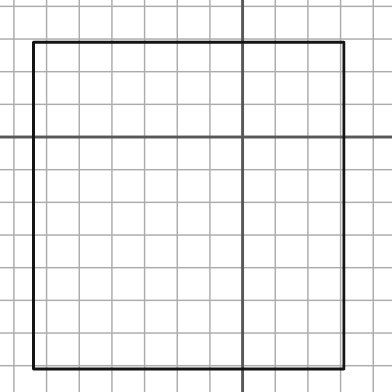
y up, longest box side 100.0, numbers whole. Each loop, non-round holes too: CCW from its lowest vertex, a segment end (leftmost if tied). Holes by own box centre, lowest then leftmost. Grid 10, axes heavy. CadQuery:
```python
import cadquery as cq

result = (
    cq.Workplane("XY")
    .moveTo(-64.0, -71.0)
    .lineTo(31.0, -71.0)
    .lineTo(31.0, 29.0)
    .lineTo(-64.0, 29.0)
    .close()
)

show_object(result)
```